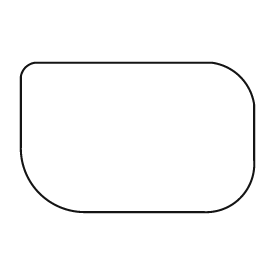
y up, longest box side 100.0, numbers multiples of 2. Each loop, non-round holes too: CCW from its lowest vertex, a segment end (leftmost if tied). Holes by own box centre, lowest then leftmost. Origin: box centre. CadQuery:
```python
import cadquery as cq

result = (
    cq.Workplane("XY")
    .moveTo(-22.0, -32.0)
    .lineTo(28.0, -32.0)
    .threePointArc((44.0, -26.0), (50.0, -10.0))
    .lineTo(50.0, 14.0)
    .threePointArc((44.0, 26.0), (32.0, 32.0))
    .lineTo(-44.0, 32.0)
    .threePointArc((-48.0, 30.0), (-50.0, 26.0))
    .lineTo(-50.0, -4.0)
    .threePointArc((-42.0, -24.0), (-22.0, -32.0))
    .close()
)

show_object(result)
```